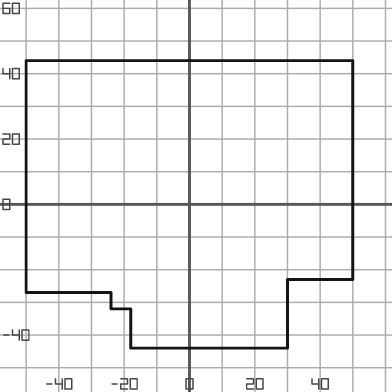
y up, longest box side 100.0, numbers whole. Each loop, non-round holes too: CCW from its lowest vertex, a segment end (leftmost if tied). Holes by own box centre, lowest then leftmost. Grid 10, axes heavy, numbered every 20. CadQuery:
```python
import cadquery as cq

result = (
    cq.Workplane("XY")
    .moveTo(-18.0, -44.0)
    .lineTo(30.0, -44.0)
    .lineTo(30.0, -23.0)
    .lineTo(50.0, -23.0)
    .lineTo(50.0, 44.0)
    .lineTo(-50.0, 44.0)
    .lineTo(-50.0, -27.0)
    .lineTo(-24.0, -27.0)
    .lineTo(-24.0, -32.0)
    .lineTo(-18.0, -32.0)
    .close()
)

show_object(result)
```